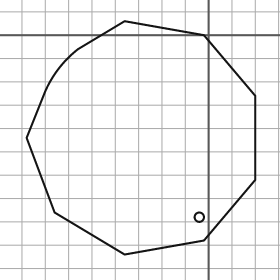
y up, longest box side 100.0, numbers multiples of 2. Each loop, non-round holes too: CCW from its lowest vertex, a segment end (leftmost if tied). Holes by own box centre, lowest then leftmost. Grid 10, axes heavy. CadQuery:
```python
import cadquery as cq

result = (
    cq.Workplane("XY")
    .moveTo(-36.0, -94.0)
    .lineTo(-2.0, -88.0)
    .lineTo(20.0, -62.0)
    .lineTo(20.0, -26.0)
    .lineTo(-2.0, 0.0)
    .lineTo(-36.0, 6.0)
    .lineTo(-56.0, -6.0)
    .threePointArc((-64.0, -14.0), (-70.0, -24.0))
    .lineTo(-78.0, -44.0)
    .lineTo(-66.0, -76.0)
    .close()
    .moveTo(-4.0, -78.0)
    .circle(2.0)
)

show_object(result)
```